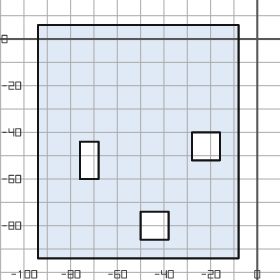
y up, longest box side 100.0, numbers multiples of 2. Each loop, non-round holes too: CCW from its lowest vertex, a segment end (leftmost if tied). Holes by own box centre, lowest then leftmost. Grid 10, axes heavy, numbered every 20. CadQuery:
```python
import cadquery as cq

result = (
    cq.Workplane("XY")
    .moveTo(-94.0, -94.0)
    .lineTo(-8.0, -94.0)
    .lineTo(-8.0, 6.0)
    .lineTo(-94.0, 6.0)
    .close()
    .moveTo(-50.0, -86.0)
    .lineTo(-38.0, -86.0)
    .lineTo(-38.0, -74.0)
    .lineTo(-50.0, -74.0)
    .close()
    .moveTo(-76.0, -60.0)
    .lineTo(-68.0, -60.0)
    .lineTo(-68.0, -44.0)
    .lineTo(-76.0, -44.0)
    .close()
    .moveTo(-28.0, -52.0)
    .lineTo(-16.0, -52.0)
    .lineTo(-16.0, -40.0)
    .lineTo(-28.0, -40.0)
    .close()
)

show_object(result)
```